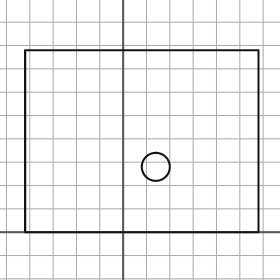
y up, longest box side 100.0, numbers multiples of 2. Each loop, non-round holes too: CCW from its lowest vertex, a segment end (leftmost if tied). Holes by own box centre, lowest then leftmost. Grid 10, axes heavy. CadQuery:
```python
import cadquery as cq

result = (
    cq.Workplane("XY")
    .moveTo(-42.0, 0.0)
    .lineTo(58.0, 0.0)
    .lineTo(58.0, 78.0)
    .lineTo(-42.0, 78.0)
    .close()
    .moveTo(14.0, 28.0)
    .circle(6.0)
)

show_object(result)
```